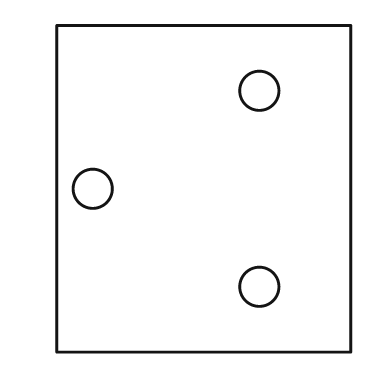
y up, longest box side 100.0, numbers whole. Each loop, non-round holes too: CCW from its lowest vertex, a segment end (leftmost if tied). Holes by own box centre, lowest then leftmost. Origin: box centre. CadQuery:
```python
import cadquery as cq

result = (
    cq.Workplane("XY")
    .moveTo(-45.0, -50.0)
    .lineTo(45.0, -50.0)
    .lineTo(45.0, 50.0)
    .lineTo(-45.0, 50.0)
    .close()
    .moveTo(17.0, -30.0)
    .circle(6.0)
    .moveTo(-34.0, 0.0)
    .circle(6.0)
    .moveTo(17.0, 30.0)
    .circle(6.0)
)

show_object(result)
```